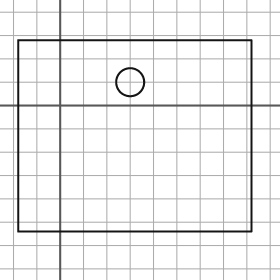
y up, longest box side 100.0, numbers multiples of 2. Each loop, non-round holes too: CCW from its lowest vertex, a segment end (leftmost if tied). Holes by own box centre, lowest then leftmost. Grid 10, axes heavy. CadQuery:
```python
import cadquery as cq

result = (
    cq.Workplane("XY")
    .moveTo(-18.0, -54.0)
    .lineTo(82.0, -54.0)
    .lineTo(82.0, 28.0)
    .lineTo(-18.0, 28.0)
    .close()
    .moveTo(30.0, 10.0)
    .circle(6.0)
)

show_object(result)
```